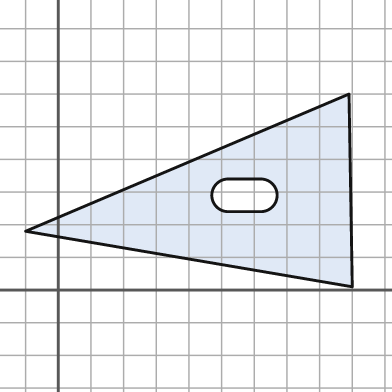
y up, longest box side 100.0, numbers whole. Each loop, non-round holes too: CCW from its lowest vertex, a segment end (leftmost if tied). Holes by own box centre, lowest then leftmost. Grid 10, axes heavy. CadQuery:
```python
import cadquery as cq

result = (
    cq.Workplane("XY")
    .moveTo(90.0, 1.0)
    .lineTo(89.0, 60.0)
    .lineTo(-10.0, 18.0)
    .close()
    .moveTo(52.0, 24.0)
    .lineTo(62.0, 24.0)
    .threePointArc((67.0, 29.0), (62.0, 34.0))
    .lineTo(52.0, 34.0)
    .threePointArc((47.0, 29.0), (52.0, 24.0))
    .close()
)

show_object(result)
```